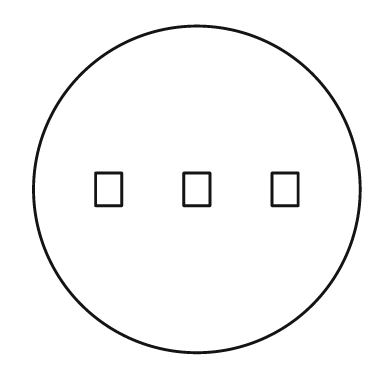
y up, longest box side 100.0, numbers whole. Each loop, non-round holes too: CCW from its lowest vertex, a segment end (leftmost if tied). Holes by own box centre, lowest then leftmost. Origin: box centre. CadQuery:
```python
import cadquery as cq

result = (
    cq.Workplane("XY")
    .moveTo(0.0, 0.0)
    .circle(50.0)
    .moveTo(-31.0, -5.0)
    .lineTo(-23.0, -5.0)
    .lineTo(-23.0, 5.0)
    .lineTo(-31.0, 5.0)
    .close()
    .moveTo(-4.0, -5.0)
    .lineTo(4.0, -5.0)
    .lineTo(4.0, 5.0)
    .lineTo(-4.0, 5.0)
    .close()
    .moveTo(23.0, -5.0)
    .lineTo(31.0, -5.0)
    .lineTo(31.0, 5.0)
    .lineTo(23.0, 5.0)
    .close()
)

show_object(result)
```